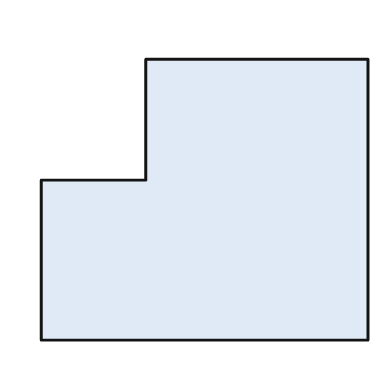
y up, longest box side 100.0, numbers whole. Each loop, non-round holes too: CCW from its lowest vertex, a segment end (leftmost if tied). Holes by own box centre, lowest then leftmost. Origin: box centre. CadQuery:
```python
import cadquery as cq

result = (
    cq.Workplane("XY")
    .moveTo(-50.0, -43.0)
    .lineTo(50.0, -43.0)
    .lineTo(50.0, 43.0)
    .lineTo(-18.0, 43.0)
    .lineTo(-18.0, 6.0)
    .lineTo(-50.0, 6.0)
    .close()
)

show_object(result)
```